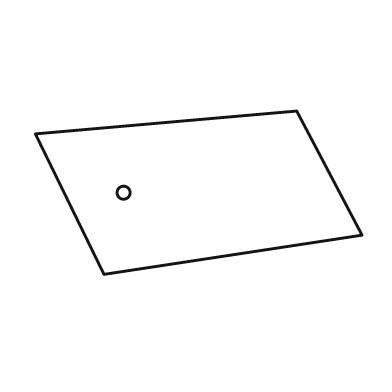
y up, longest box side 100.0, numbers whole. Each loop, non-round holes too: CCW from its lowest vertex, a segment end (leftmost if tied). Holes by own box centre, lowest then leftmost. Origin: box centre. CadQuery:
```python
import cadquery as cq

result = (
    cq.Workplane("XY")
    .moveTo(-29.0, -25.0)
    .lineTo(50.0, -13.0)
    .lineTo(30.0, 25.0)
    .lineTo(-50.0, 18.0)
    .close()
    .moveTo(-23.0, 0.0)
    .circle(2.0)
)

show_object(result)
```